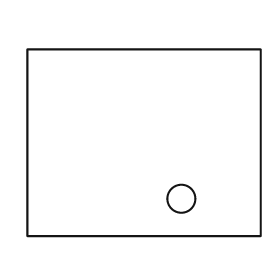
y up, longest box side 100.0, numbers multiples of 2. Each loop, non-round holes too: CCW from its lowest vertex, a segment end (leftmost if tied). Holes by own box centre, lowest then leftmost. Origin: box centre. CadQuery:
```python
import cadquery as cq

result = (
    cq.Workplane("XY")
    .moveTo(-50.0, -40.0)
    .lineTo(50.0, -40.0)
    .lineTo(50.0, 40.0)
    .lineTo(-50.0, 40.0)
    .close()
    .moveTo(16.0, -24.0)
    .circle(6.0)
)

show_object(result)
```